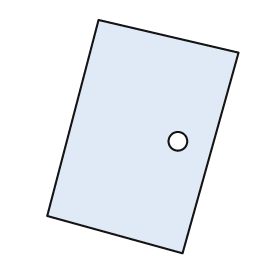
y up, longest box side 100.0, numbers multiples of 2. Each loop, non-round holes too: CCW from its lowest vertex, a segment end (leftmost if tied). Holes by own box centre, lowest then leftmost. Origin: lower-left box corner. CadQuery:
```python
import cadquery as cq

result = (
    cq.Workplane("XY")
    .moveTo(58.0, 0.0)
    .lineTo(82.0, 86.0)
    .lineTo(22.0, 100.0)
    .lineTo(0.0, 16.0)
    .close()
    .moveTo(56.0, 48.0)
    .circle(4.0)
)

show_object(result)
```